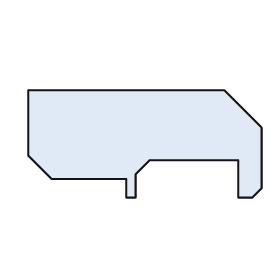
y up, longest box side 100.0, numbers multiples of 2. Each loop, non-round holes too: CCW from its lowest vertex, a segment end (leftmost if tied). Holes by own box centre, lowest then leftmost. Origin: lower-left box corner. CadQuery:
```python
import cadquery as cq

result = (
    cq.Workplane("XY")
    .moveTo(42.0, 0.0)
    .lineTo(46.0, 0.0)
    .lineTo(46.0, 10.0)
    .lineTo(52.0, 16.0)
    .lineTo(90.0, 16.0)
    .lineTo(90.0, 0.0)
    .lineTo(96.0, 0.0)
    .lineTo(100.0, 4.0)
    .lineTo(100.0, 30.0)
    .lineTo(84.0, 46.0)
    .lineTo(0.0, 46.0)
    .lineTo(0.0, 18.0)
    .lineTo(10.0, 8.0)
    .lineTo(42.0, 8.0)
    .close()
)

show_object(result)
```